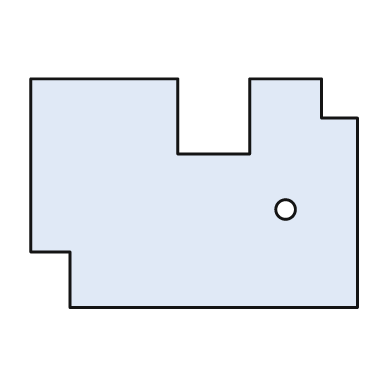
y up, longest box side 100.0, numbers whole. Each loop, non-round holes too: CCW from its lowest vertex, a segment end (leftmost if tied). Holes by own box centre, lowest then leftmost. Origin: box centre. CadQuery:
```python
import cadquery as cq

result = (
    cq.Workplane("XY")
    .moveTo(-38.0, -35.0)
    .lineTo(50.0, -35.0)
    .lineTo(50.0, 23.0)
    .lineTo(39.0, 23.0)
    .lineTo(39.0, 35.0)
    .lineTo(17.0, 35.0)
    .lineTo(17.0, 12.0)
    .lineTo(-5.0, 12.0)
    .lineTo(-5.0, 35.0)
    .lineTo(-50.0, 35.0)
    .lineTo(-50.0, -18.0)
    .lineTo(-38.0, -18.0)
    .close()
    .moveTo(28.0, -5.0)
    .circle(3.0)
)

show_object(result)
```